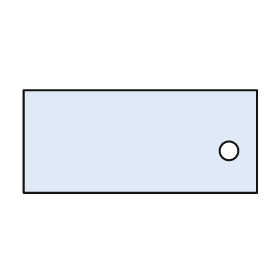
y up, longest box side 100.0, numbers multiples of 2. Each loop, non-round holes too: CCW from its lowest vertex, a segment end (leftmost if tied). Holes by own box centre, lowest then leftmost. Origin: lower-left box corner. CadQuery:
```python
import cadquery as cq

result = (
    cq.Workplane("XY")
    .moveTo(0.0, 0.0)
    .lineTo(100.0, 0.0)
    .lineTo(100.0, 44.0)
    .lineTo(0.0, 44.0)
    .close()
    .moveTo(88.0, 18.0)
    .circle(4.0)
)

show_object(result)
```